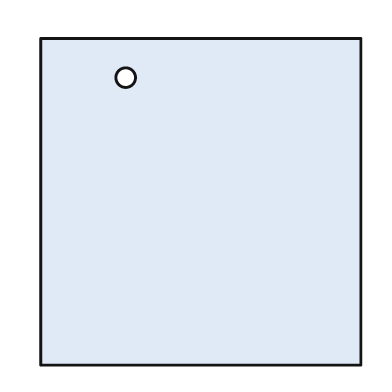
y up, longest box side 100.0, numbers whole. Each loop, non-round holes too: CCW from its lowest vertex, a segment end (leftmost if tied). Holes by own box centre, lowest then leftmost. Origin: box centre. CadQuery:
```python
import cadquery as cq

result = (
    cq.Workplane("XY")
    .moveTo(-49.0, -50.0)
    .lineTo(49.0, -50.0)
    .lineTo(49.0, 50.0)
    .lineTo(-49.0, 50.0)
    .close()
    .moveTo(-23.0, 38.0)
    .circle(3.0)
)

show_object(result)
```